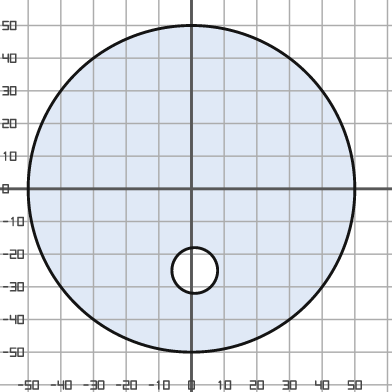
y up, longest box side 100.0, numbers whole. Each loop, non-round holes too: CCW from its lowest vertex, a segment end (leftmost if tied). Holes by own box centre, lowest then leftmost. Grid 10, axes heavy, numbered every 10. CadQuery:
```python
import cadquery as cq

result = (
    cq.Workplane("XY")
    .moveTo(0.0, 0.0)
    .circle(50.0)
    .moveTo(1.0, -25.0)
    .circle(7.0)
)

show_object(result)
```